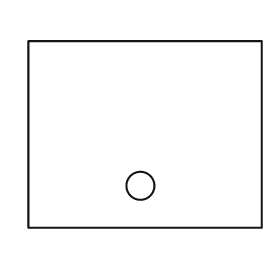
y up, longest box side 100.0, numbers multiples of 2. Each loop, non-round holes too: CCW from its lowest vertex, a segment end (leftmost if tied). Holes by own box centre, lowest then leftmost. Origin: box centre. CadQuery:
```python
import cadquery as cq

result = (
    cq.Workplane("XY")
    .moveTo(-50.0, -40.0)
    .lineTo(50.0, -40.0)
    .lineTo(50.0, 40.0)
    .lineTo(-50.0, 40.0)
    .close()
    .moveTo(-2.0, -22.0)
    .circle(6.0)
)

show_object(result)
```